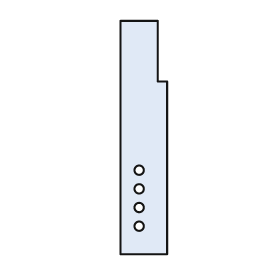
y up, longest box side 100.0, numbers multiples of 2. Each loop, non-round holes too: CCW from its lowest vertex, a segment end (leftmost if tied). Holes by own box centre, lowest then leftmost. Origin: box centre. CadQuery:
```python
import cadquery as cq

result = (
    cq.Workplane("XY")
    .moveTo(-10.0, -50.0)
    .lineTo(10.0, -50.0)
    .lineTo(10.0, 24.0)
    .lineTo(6.0, 24.0)
    .lineTo(6.0, 50.0)
    .lineTo(-10.0, 50.0)
    .close()
    .moveTo(-2.0, -38.0)
    .circle(2.0)
    .moveTo(-2.0, -30.0)
    .circle(2.0)
    .moveTo(-2.0, -22.0)
    .circle(2.0)
    .moveTo(-2.0, -14.0)
    .circle(2.0)
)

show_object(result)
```